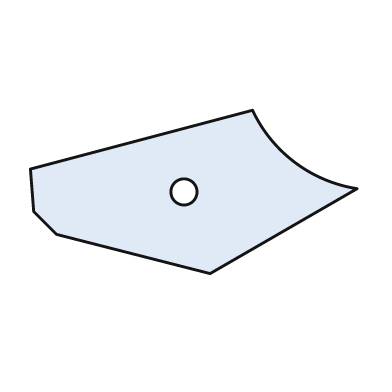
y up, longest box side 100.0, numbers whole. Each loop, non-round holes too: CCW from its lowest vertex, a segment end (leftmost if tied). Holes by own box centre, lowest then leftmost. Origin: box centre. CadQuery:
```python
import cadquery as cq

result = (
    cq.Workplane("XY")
    .moveTo(5.0, -25.0)
    .lineTo(50.0, 1.0)
    .threePointArc((31.0, 9.0), (18.0, 25.0))
    .lineTo(-50.0, 7.0)
    .lineTo(-49.0, -6.0)
    .lineTo(-42.0, -13.0)
    .close()
    .moveTo(-3.0, 0.0)
    .circle(4.0)
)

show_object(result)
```